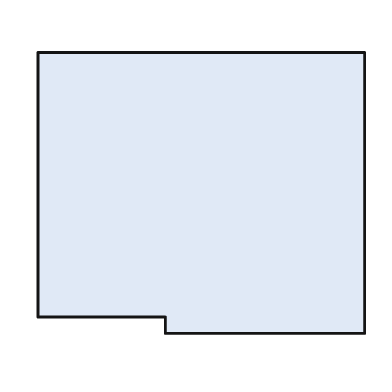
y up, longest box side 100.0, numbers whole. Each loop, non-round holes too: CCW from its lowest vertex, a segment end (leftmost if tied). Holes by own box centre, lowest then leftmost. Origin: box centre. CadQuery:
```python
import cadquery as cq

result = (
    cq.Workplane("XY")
    .moveTo(-11.0, -43.0)
    .lineTo(50.0, -43.0)
    .lineTo(50.0, 43.0)
    .lineTo(-50.0, 43.0)
    .lineTo(-50.0, -38.0)
    .lineTo(-11.0, -38.0)
    .close()
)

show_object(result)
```